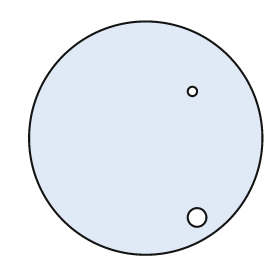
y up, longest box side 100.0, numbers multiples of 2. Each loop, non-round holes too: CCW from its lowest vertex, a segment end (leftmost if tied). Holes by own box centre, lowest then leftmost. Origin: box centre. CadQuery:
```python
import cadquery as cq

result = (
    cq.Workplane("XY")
    .moveTo(0.0, 0.0)
    .circle(50.0)
    .moveTo(22.0, -34.0)
    .circle(4.0)
    .moveTo(20.0, 20.0)
    .circle(2.0)
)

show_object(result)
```